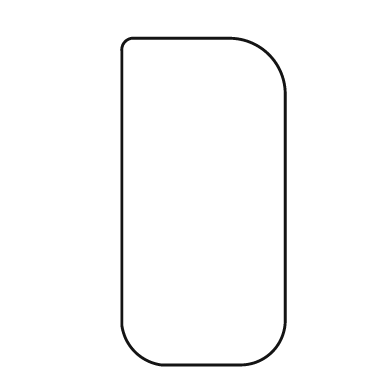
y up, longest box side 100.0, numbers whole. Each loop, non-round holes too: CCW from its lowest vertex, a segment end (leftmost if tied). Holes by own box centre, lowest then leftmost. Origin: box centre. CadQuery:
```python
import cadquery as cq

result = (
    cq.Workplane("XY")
    .moveTo(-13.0, -50.0)
    .lineTo(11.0, -50.0)
    .threePointArc((21.0, -46.0), (25.0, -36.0))
    .lineTo(25.0, 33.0)
    .threePointArc((20.0, 45.0), (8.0, 50.0))
    .lineTo(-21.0, 50.0)
    .threePointArc((-24.0, 49.0), (-25.0, 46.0))
    .lineTo(-25.0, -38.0)
    .threePointArc((-21.0, -46.0), (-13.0, -50.0))
    .close()
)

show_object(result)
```